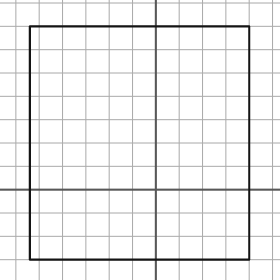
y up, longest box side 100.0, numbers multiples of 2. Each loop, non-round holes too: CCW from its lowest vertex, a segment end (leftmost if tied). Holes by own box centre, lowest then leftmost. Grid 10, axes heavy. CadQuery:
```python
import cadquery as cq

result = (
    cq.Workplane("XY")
    .moveTo(-54.0, -30.0)
    .lineTo(40.0, -30.0)
    .lineTo(40.0, 70.0)
    .lineTo(-54.0, 70.0)
    .close()
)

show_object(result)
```